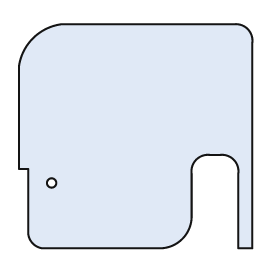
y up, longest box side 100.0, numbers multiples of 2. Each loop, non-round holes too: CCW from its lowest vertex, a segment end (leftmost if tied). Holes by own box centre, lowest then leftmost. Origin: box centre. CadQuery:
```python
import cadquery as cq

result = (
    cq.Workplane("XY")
    .moveTo(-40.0, -48.0)
    .lineTo(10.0, -48.0)
    .threePointArc((20.0, -44.0), (24.0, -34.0))
    .lineTo(24.0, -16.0)
    .threePointArc((26.0, -10.0), (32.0, -8.0))
    .lineTo(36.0, -8.0)
    .threePointArc((42.0, -10.0), (44.0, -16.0))
    .lineTo(44.0, -48.0)
    .lineTo(50.0, -48.0)
    .lineTo(50.0, 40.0)
    .threePointArc((48.0, 46.0), (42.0, 48.0))
    .lineTo(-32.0, 48.0)
    .threePointArc((-44.0, 42.0), (-50.0, 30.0))
    .lineTo(-50.0, -14.0)
    .lineTo(-46.0, -14.0)
    .lineTo(-46.0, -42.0)
    .threePointArc((-44.0, -46.0), (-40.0, -48.0))
    .close()
    .moveTo(-36.0, -20.0)
    .circle(2.0)
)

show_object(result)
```